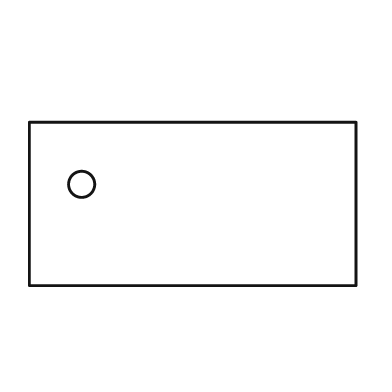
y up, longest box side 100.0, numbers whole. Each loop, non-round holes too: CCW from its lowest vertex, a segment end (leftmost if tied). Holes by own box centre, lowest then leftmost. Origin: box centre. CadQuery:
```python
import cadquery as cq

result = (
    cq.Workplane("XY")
    .moveTo(-50.0, -25.0)
    .lineTo(50.0, -25.0)
    .lineTo(50.0, 25.0)
    .lineTo(-50.0, 25.0)
    .close()
    .moveTo(-34.0, 6.0)
    .circle(4.0)
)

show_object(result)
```